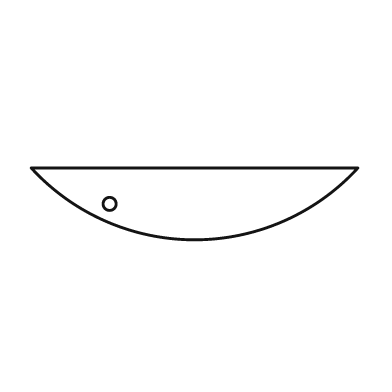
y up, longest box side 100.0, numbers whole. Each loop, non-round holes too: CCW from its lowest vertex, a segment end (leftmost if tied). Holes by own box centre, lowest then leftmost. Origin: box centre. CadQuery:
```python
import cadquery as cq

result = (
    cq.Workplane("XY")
    .moveTo(-50.0, 11.0)
    .threePointArc((0.0, -11.0), (50.0, 11.0))
    .close()
    .moveTo(-26.0, 0.0)
    .circle(2.0)
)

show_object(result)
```